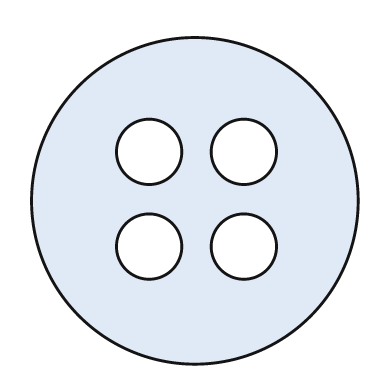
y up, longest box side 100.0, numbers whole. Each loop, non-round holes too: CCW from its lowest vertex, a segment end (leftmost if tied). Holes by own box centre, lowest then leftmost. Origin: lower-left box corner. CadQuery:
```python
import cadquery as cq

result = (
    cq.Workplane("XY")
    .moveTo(50.0, 50.0)
    .circle(50.0)
    .moveTo(36.0, 36.0)
    .circle(10.0)
    .moveTo(65.0, 36.0)
    .circle(10.0)
    .moveTo(36.0, 65.0)
    .circle(10.0)
    .moveTo(65.0, 65.0)
    .circle(10.0)
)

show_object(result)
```